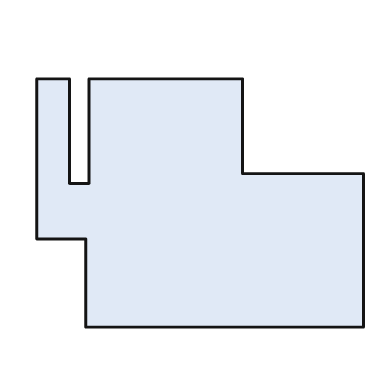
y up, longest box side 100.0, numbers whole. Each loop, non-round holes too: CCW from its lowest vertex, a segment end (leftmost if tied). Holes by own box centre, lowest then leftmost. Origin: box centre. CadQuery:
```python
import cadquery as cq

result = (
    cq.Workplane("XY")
    .moveTo(-35.0, -38.0)
    .lineTo(50.0, -38.0)
    .lineTo(50.0, 9.0)
    .lineTo(13.0, 9.0)
    .lineTo(13.0, 38.0)
    .lineTo(-34.0, 38.0)
    .lineTo(-34.0, 6.0)
    .lineTo(-40.0, 6.0)
    .lineTo(-40.0, 38.0)
    .lineTo(-50.0, 38.0)
    .lineTo(-50.0, -11.0)
    .lineTo(-35.0, -11.0)
    .close()
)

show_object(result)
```